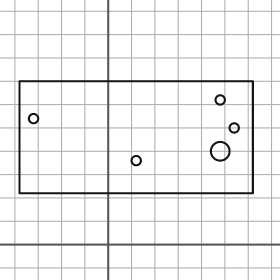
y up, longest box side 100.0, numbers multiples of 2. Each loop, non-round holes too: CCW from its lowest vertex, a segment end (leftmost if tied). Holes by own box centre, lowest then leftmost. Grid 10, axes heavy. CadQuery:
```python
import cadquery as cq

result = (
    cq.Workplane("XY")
    .moveTo(-38.0, 22.0)
    .lineTo(62.0, 22.0)
    .lineTo(62.0, 70.0)
    .lineTo(-38.0, 70.0)
    .close()
    .moveTo(12.0, 36.0)
    .circle(2.0)
    .moveTo(48.0, 40.0)
    .circle(4.0)
    .moveTo(54.0, 50.0)
    .circle(2.0)
    .moveTo(-32.0, 54.0)
    .circle(2.0)
    .moveTo(48.0, 62.0)
    .circle(2.0)
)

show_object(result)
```